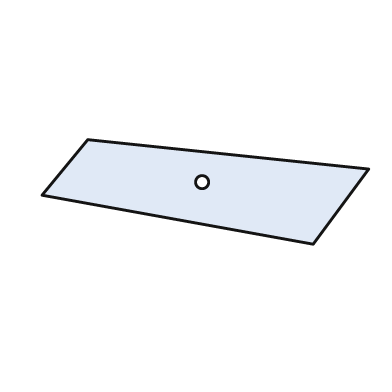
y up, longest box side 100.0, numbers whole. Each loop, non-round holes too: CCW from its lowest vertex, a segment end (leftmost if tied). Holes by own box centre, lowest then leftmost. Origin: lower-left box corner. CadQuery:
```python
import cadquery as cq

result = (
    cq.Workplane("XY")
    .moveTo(83.0, 0.0)
    .lineTo(100.0, 23.0)
    .lineTo(14.0, 32.0)
    .lineTo(0.0, 15.0)
    .close()
    .moveTo(49.0, 19.0)
    .circle(2.0)
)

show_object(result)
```